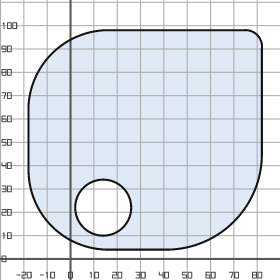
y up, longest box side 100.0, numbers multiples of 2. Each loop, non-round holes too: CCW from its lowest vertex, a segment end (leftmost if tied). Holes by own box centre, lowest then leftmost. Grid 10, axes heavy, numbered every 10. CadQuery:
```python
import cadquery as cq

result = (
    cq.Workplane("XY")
    .moveTo(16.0, 4.0)
    .lineTo(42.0, 4.0)
    .threePointArc((70.0, 16.0), (82.0, 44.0))
    .lineTo(82.0, 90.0)
    .threePointArc((80.0, 96.0), (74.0, 98.0))
    .lineTo(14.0, 98.0)
    .threePointArc((-8.0, 88.0), (-18.0, 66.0))
    .lineTo(-18.0, 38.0)
    .threePointArc((-8.0, 14.0), (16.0, 4.0))
    .close()
    .moveTo(14.0, 22.0)
    .circle(12.0)
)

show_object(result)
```